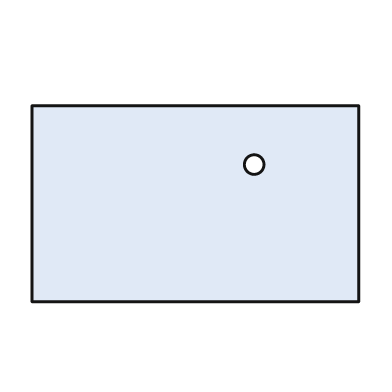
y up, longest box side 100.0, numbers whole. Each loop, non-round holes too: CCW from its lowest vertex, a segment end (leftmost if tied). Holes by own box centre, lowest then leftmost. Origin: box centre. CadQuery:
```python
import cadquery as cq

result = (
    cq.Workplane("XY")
    .moveTo(-50.0, -30.0)
    .lineTo(50.0, -30.0)
    .lineTo(50.0, 30.0)
    .lineTo(-50.0, 30.0)
    .close()
    .moveTo(18.0, 12.0)
    .circle(3.0)
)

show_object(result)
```